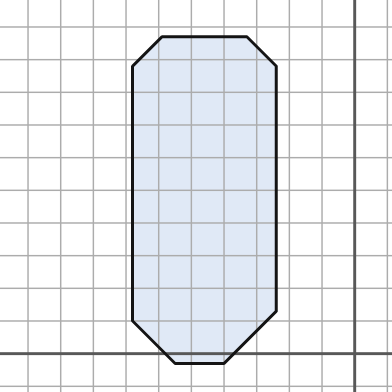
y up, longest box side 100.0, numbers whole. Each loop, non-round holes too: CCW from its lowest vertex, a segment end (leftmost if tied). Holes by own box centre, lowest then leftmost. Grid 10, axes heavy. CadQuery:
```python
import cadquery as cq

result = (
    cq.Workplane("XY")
    .moveTo(-55.0, -3.0)
    .lineTo(-40.0, -3.0)
    .lineTo(-24.0, 13.0)
    .lineTo(-24.0, 88.0)
    .lineTo(-33.0, 97.0)
    .lineTo(-59.0, 97.0)
    .lineTo(-68.0, 88.0)
    .lineTo(-68.0, 10.0)
    .close()
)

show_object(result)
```